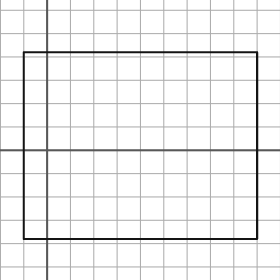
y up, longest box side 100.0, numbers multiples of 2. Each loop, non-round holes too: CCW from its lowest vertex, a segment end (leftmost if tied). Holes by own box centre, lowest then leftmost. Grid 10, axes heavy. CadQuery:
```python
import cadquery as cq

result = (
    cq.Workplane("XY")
    .moveTo(-10.0, -38.0)
    .lineTo(90.0, -38.0)
    .lineTo(90.0, 42.0)
    .lineTo(-10.0, 42.0)
    .close()
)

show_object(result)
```